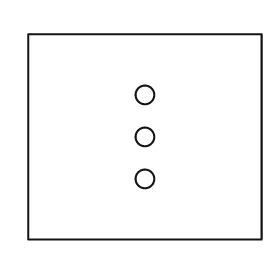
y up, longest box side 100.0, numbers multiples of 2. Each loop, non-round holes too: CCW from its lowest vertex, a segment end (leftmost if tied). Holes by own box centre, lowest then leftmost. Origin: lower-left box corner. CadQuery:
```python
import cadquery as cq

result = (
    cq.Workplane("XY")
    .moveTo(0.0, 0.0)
    .lineTo(100.0, 0.0)
    .lineTo(100.0, 88.0)
    .lineTo(0.0, 88.0)
    .close()
    .moveTo(50.0, 26.0)
    .circle(4.0)
    .moveTo(50.0, 44.0)
    .circle(4.0)
    .moveTo(50.0, 62.0)
    .circle(4.0)
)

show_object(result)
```